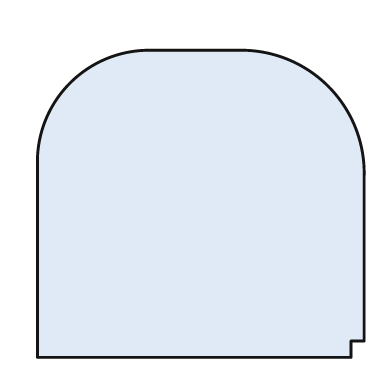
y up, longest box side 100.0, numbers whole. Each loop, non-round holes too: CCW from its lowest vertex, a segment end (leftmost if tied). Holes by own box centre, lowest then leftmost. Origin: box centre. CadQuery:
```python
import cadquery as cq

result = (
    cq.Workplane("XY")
    .moveTo(-50.0, -47.0)
    .lineTo(46.0, -47.0)
    .lineTo(46.0, -42.0)
    .lineTo(50.0, -42.0)
    .lineTo(50.0, 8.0)
    .threePointArc((39.0, 36.0), (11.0, 47.0))
    .lineTo(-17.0, 47.0)
    .threePointArc((-40.0, 37.0), (-50.0, 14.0))
    .close()
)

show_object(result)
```